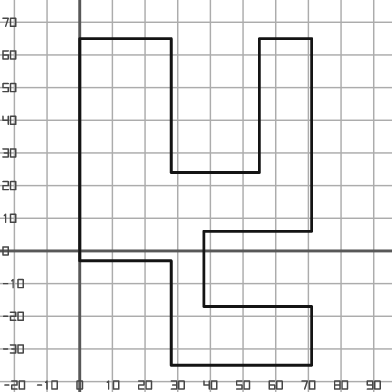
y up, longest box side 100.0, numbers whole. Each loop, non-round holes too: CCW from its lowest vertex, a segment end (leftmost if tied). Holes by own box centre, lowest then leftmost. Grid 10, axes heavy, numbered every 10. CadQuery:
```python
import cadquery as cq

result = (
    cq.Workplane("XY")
    .moveTo(28.0, -35.0)
    .lineTo(71.0, -35.0)
    .lineTo(71.0, -17.0)
    .lineTo(38.0, -17.0)
    .lineTo(38.0, 6.0)
    .lineTo(71.0, 6.0)
    .lineTo(71.0, 65.0)
    .lineTo(55.0, 65.0)
    .lineTo(55.0, 24.0)
    .lineTo(28.0, 24.0)
    .lineTo(28.0, 65.0)
    .lineTo(0.0, 65.0)
    .lineTo(0.0, -3.0)
    .lineTo(28.0, -3.0)
    .close()
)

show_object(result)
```